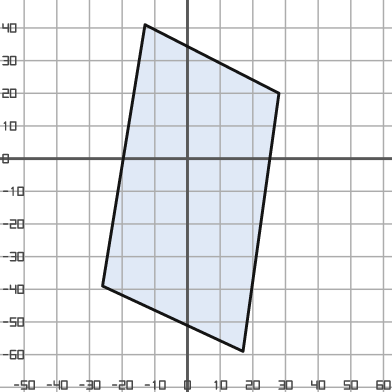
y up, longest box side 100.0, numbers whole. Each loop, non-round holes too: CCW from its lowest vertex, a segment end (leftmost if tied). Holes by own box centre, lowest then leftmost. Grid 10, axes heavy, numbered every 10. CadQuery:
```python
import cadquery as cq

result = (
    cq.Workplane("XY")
    .moveTo(17.0, -59.0)
    .lineTo(28.0, 20.0)
    .lineTo(-13.0, 41.0)
    .lineTo(-26.0, -39.0)
    .close()
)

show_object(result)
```